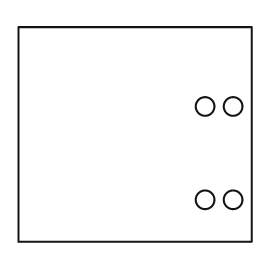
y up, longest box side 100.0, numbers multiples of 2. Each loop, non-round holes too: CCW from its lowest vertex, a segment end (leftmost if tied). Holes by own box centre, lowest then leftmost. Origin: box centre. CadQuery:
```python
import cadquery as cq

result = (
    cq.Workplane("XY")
    .moveTo(-50.0, -46.0)
    .lineTo(50.0, -46.0)
    .lineTo(50.0, 46.0)
    .lineTo(-50.0, 46.0)
    .close()
    .moveTo(30.0, -28.0)
    .circle(4.0)
    .moveTo(42.0, -28.0)
    .circle(4.0)
    .moveTo(30.0, 12.0)
    .circle(4.0)
    .moveTo(42.0, 12.0)
    .circle(4.0)
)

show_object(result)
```